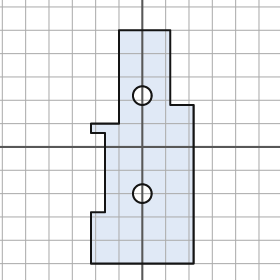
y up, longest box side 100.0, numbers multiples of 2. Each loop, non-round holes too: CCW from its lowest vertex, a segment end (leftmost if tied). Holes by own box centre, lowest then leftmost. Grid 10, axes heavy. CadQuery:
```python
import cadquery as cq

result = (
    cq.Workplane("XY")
    .moveTo(-22.0, -50.0)
    .lineTo(22.0, -50.0)
    .lineTo(22.0, 18.0)
    .lineTo(12.0, 18.0)
    .lineTo(12.0, 50.0)
    .lineTo(-10.0, 50.0)
    .lineTo(-10.0, 10.0)
    .lineTo(-22.0, 10.0)
    .lineTo(-22.0, 6.0)
    .lineTo(-16.0, 6.0)
    .lineTo(-16.0, -28.0)
    .lineTo(-22.0, -28.0)
    .close()
    .moveTo(0.0, -20.0)
    .circle(4.0)
    .moveTo(0.0, 22.0)
    .circle(4.0)
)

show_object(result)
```